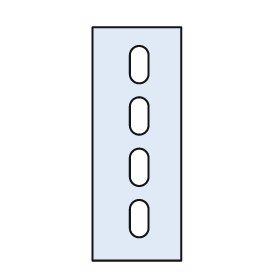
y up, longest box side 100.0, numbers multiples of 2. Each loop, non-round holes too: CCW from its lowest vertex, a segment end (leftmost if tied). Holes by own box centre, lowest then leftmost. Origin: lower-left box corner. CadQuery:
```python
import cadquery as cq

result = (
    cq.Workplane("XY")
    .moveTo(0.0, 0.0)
    .lineTo(38.0, 0.0)
    .lineTo(38.0, 100.0)
    .lineTo(0.0, 100.0)
    .close()
    .moveTo(16.0, 14.0)
    .threePointArc((20.0, 10.0), (24.0, 14.0))
    .lineTo(24.0, 22.0)
    .threePointArc((20.0, 26.0), (16.0, 22.0))
    .close()
    .moveTo(16.0, 36.0)
    .threePointArc((20.0, 32.0), (24.0, 36.0))
    .lineTo(24.0, 44.0)
    .threePointArc((20.0, 48.0), (16.0, 44.0))
    .close()
    .moveTo(16.0, 58.0)
    .threePointArc((20.0, 54.0), (24.0, 58.0))
    .lineTo(24.0, 66.0)
    .threePointArc((20.0, 70.0), (16.0, 66.0))
    .close()
    .moveTo(16.0, 80.0)
    .threePointArc((20.0, 76.0), (24.0, 80.0))
    .lineTo(24.0, 88.0)
    .threePointArc((20.0, 92.0), (16.0, 88.0))
    .close()
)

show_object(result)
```